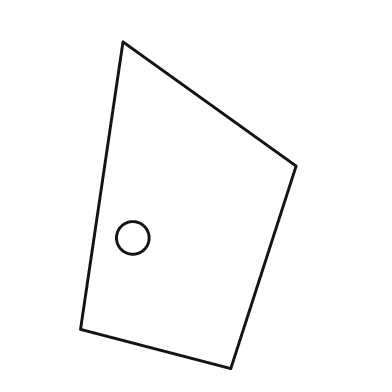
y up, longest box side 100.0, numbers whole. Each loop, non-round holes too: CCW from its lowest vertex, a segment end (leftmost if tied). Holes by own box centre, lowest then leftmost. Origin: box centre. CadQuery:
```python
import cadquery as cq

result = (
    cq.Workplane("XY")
    .moveTo(13.0, -50.0)
    .lineTo(33.0, 12.0)
    .lineTo(-20.0, 50.0)
    .lineTo(-33.0, -38.0)
    .close()
    .moveTo(-17.0, -10.0)
    .circle(5.0)
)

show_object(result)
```